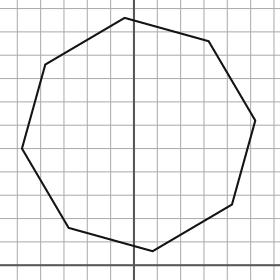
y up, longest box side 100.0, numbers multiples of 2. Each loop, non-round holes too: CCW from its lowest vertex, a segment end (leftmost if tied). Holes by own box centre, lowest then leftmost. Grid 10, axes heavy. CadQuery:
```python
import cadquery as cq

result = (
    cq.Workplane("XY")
    .moveTo(8.0, 6.0)
    .lineTo(42.0, 26.0)
    .lineTo(52.0, 62.0)
    .lineTo(32.0, 96.0)
    .lineTo(-4.0, 106.0)
    .lineTo(-38.0, 86.0)
    .lineTo(-48.0, 50.0)
    .lineTo(-28.0, 16.0)
    .close()
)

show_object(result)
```